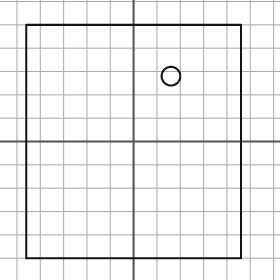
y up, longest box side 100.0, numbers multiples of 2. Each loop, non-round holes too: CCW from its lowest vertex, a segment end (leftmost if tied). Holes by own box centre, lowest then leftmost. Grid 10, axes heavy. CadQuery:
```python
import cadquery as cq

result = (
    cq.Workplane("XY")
    .moveTo(-46.0, -50.0)
    .lineTo(46.0, -50.0)
    .lineTo(46.0, 50.0)
    .lineTo(-46.0, 50.0)
    .close()
    .moveTo(16.0, 28.0)
    .circle(4.0)
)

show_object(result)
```